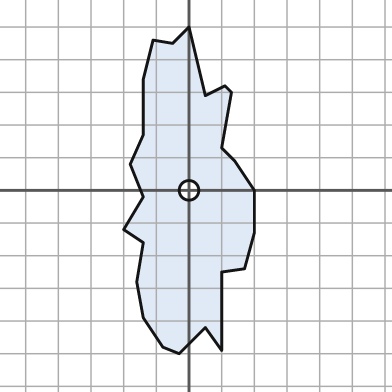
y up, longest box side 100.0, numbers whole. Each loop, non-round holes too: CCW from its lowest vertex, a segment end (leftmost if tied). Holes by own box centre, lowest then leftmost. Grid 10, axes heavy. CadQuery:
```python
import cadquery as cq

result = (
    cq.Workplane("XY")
    .moveTo(-3.0, -50.0)
    .lineTo(5.0, -42.0)
    .lineTo(10.0, -49.0)
    .lineTo(10.0, -25.0)
    .lineTo(17.0, -24.0)
    .lineTo(20.0, -13.0)
    .lineTo(20.0, 0.0)
    .lineTo(14.0, 9.0)
    .lineTo(10.0, 13.0)
    .lineTo(13.0, 30.0)
    .lineTo(11.0, 32.0)
    .lineTo(5.0, 29.0)
    .lineTo(0.0, 50.0)
    .lineTo(-5.0, 45.0)
    .lineTo(-11.0, 46.0)
    .lineTo(-14.0, 34.0)
    .lineTo(-14.0, 17.0)
    .lineTo(-18.0, 8.0)
    .lineTo(-14.0, -2.0)
    .lineTo(-20.0, -12.0)
    .lineTo(-14.0, -16.0)
    .lineTo(-16.0, -28.0)
    .lineTo(-14.0, -39.0)
    .lineTo(-8.0, -48.0)
    .close()
    .moveTo(0.0, 0.0)
    .circle(3.0)
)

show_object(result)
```